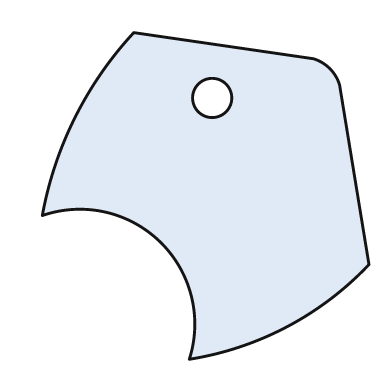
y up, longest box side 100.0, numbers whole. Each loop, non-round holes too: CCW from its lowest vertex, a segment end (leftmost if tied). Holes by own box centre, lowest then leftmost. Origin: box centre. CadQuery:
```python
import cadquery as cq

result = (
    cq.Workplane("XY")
    .moveTo(-5.0, -50.0)
    .threePointArc((25.0, -40.0), (50.0, -21.0))
    .lineTo(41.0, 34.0)
    .threePointArc((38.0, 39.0), (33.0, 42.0))
    .lineTo(-22.0, 50.0)
    .threePointArc((-40.0, 24.0), (-50.0, -6.0))
    .threePointArc((-14.0, -14.0), (-5.0, -50.0))
    .close()
    .moveTo(2.0, 30.0)
    .circle(6.0)
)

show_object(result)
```